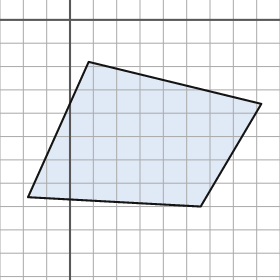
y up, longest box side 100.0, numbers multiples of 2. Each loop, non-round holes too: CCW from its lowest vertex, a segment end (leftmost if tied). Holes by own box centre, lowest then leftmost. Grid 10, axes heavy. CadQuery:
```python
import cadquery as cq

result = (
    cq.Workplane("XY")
    .moveTo(56.0, -80.0)
    .lineTo(82.0, -36.0)
    .lineTo(8.0, -18.0)
    .lineTo(-18.0, -76.0)
    .close()
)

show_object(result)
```